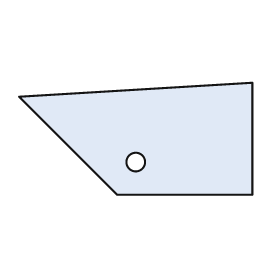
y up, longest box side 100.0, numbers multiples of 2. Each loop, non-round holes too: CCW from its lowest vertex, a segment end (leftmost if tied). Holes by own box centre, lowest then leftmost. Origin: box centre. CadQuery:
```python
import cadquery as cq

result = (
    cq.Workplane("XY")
    .moveTo(-8.0, -24.0)
    .lineTo(50.0, -24.0)
    .lineTo(50.0, 24.0)
    .lineTo(-50.0, 18.0)
    .close()
    .moveTo(0.0, -10.0)
    .circle(4.0)
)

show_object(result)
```